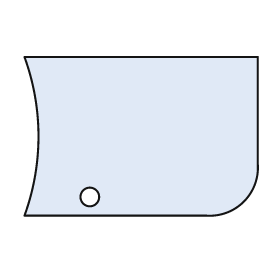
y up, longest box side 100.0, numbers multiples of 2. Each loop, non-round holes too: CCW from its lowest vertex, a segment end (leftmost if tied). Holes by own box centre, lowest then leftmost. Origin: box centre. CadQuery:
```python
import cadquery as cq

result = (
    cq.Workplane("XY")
    .moveTo(-50.0, -34.0)
    .lineTo(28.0, -34.0)
    .threePointArc((44.0, -28.0), (50.0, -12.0))
    .lineTo(50.0, 34.0)
    .lineTo(-50.0, 34.0)
    .threePointArc((-44.0, 0.0), (-50.0, -34.0))
    .close()
    .moveTo(-22.0, -26.0)
    .circle(4.0)
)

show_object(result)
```